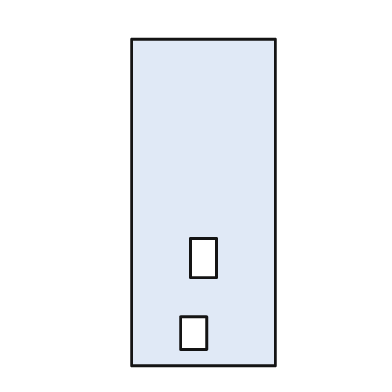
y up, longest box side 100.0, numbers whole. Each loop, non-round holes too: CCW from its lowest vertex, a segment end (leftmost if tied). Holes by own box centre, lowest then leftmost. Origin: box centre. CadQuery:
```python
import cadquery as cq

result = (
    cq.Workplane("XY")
    .moveTo(-22.0, -50.0)
    .lineTo(22.0, -50.0)
    .lineTo(22.0, 50.0)
    .lineTo(-22.0, 50.0)
    .close()
    .moveTo(-7.0, -45.0)
    .lineTo(1.0, -45.0)
    .lineTo(1.0, -35.0)
    .lineTo(-7.0, -35.0)
    .close()
    .moveTo(-4.0, -23.0)
    .lineTo(4.0, -23.0)
    .lineTo(4.0, -11.0)
    .lineTo(-4.0, -11.0)
    .close()
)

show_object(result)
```